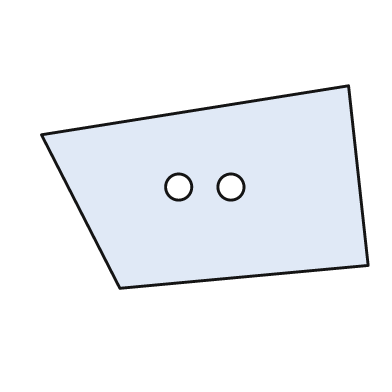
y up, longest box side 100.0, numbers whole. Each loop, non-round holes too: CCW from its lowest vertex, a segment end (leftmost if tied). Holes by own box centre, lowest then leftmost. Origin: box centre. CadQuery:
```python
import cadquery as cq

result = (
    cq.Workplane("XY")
    .moveTo(-26.0, -31.0)
    .lineTo(50.0, -24.0)
    .lineTo(44.0, 31.0)
    .lineTo(-50.0, 16.0)
    .close()
    .moveTo(-8.0, 0.0)
    .circle(4.0)
    .moveTo(8.0, 0.0)
    .circle(4.0)
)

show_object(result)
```